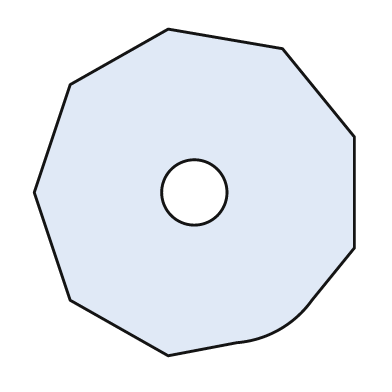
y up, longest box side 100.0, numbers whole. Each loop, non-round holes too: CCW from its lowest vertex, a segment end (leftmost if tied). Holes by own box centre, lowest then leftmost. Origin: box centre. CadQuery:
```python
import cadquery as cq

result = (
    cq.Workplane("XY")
    .moveTo(-8.0, -50.0)
    .lineTo(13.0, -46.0)
    .threePointArc((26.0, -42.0), (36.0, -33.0))
    .lineTo(49.0, -17.0)
    .lineTo(49.0, 17.0)
    .lineTo(27.0, 44.0)
    .lineTo(-8.0, 50.0)
    .lineTo(-38.0, 33.0)
    .lineTo(-49.0, 0.0)
    .lineTo(-38.0, -33.0)
    .close()
    .moveTo(0.0, 0.0)
    .circle(10.0)
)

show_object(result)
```